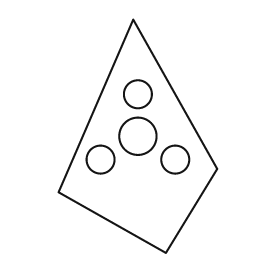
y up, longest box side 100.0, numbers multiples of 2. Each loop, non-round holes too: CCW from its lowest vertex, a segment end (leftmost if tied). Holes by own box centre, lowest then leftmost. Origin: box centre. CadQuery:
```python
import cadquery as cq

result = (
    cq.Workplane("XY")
    .moveTo(12.0, -50.0)
    .lineTo(34.0, -14.0)
    .lineTo(-2.0, 50.0)
    .lineTo(-34.0, -24.0)
    .close()
    .moveTo(-16.0, -10.0)
    .circle(6.0)
    .moveTo(16.0, -10.0)
    .circle(6.0)
    .moveTo(0.0, 0.0)
    .circle(8.0)
    .moveTo(0.0, 18.0)
    .circle(6.0)
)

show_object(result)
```